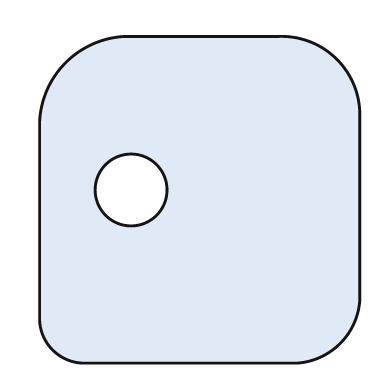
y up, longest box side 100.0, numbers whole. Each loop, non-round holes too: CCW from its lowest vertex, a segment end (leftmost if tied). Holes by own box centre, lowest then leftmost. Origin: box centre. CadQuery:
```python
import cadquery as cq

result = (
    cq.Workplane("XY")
    .moveTo(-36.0, -50.0)
    .lineTo(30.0, -50.0)
    .threePointArc((43.0, -44.0), (49.0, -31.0))
    .lineTo(49.0, 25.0)
    .threePointArc((42.0, 43.0), (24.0, 50.0))
    .lineTo(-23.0, 50.0)
    .threePointArc((-41.0, 42.0), (-49.0, 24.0))
    .lineTo(-49.0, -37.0)
    .threePointArc((-45.0, -46.0), (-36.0, -50.0))
    .close()
    .moveTo(-21.0, 3.0)
    .circle(11.0)
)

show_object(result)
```